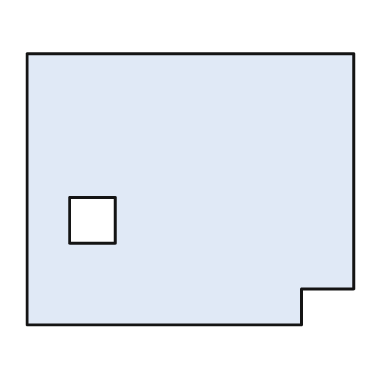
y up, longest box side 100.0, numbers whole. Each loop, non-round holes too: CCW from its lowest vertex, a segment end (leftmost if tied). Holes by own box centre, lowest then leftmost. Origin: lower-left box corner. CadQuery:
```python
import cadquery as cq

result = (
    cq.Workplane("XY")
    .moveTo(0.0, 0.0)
    .lineTo(84.0, 0.0)
    .lineTo(84.0, 11.0)
    .lineTo(100.0, 11.0)
    .lineTo(100.0, 83.0)
    .lineTo(0.0, 83.0)
    .close()
    .moveTo(13.0, 25.0)
    .lineTo(27.0, 25.0)
    .lineTo(27.0, 39.0)
    .lineTo(13.0, 39.0)
    .close()
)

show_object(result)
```